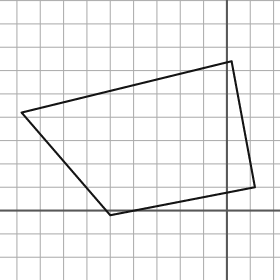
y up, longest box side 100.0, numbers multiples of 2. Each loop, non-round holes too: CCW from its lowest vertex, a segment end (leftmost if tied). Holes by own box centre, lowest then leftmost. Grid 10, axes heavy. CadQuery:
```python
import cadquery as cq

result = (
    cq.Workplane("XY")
    .moveTo(-50.0, -2.0)
    .lineTo(12.0, 10.0)
    .lineTo(2.0, 64.0)
    .lineTo(-88.0, 42.0)
    .close()
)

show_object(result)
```